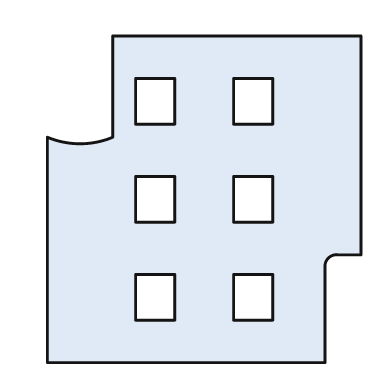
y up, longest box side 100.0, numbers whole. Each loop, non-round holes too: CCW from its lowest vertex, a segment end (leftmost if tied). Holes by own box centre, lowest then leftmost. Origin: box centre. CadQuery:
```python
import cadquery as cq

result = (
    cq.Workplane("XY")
    .moveTo(-48.0, -50.0)
    .lineTo(37.0, -50.0)
    .lineTo(37.0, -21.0)
    .threePointArc((38.0, -18.0), (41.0, -17.0))
    .lineTo(48.0, -17.0)
    .lineTo(48.0, 50.0)
    .lineTo(-28.0, 50.0)
    .lineTo(-28.0, 19.0)
    .threePointArc((-38.0, 17.0), (-48.0, 19.0))
    .close()
    .moveTo(-21.0, -37.0)
    .lineTo(-9.0, -37.0)
    .lineTo(-9.0, -23.0)
    .lineTo(-21.0, -23.0)
    .close()
    .moveTo(9.0, -37.0)
    .lineTo(21.0, -37.0)
    .lineTo(21.0, -23.0)
    .lineTo(9.0, -23.0)
    .close()
    .moveTo(-21.0, -7.0)
    .lineTo(-9.0, -7.0)
    .lineTo(-9.0, 7.0)
    .lineTo(-21.0, 7.0)
    .close()
    .moveTo(9.0, -7.0)
    .lineTo(21.0, -7.0)
    .lineTo(21.0, 7.0)
    .lineTo(9.0, 7.0)
    .close()
    .moveTo(-21.0, 23.0)
    .lineTo(-9.0, 23.0)
    .lineTo(-9.0, 37.0)
    .lineTo(-21.0, 37.0)
    .close()
    .moveTo(9.0, 23.0)
    .lineTo(21.0, 23.0)
    .lineTo(21.0, 37.0)
    .lineTo(9.0, 37.0)
    .close()
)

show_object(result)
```